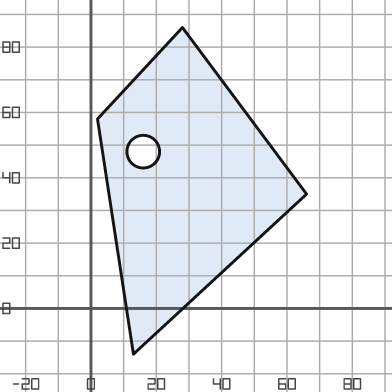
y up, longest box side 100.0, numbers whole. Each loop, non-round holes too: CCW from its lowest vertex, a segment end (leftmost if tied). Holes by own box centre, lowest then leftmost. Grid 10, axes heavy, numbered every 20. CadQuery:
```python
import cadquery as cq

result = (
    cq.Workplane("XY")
    .moveTo(13.0, -14.0)
    .lineTo(66.0, 35.0)
    .lineTo(28.0, 86.0)
    .lineTo(2.0, 58.0)
    .close()
    .moveTo(16.0, 48.0)
    .circle(5.0)
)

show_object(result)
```